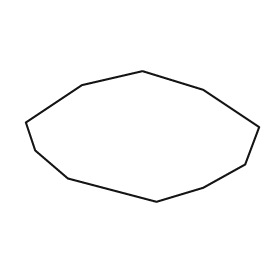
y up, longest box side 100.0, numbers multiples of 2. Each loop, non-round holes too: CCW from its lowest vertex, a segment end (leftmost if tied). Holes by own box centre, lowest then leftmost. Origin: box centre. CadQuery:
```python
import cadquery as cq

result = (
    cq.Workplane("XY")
    .moveTo(6.0, -28.0)
    .lineTo(26.0, -22.0)
    .lineTo(44.0, -12.0)
    .lineTo(50.0, 4.0)
    .lineTo(26.0, 20.0)
    .lineTo(0.0, 28.0)
    .lineTo(-26.0, 22.0)
    .lineTo(-50.0, 6.0)
    .lineTo(-46.0, -6.0)
    .lineTo(-32.0, -18.0)
    .close()
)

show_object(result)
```